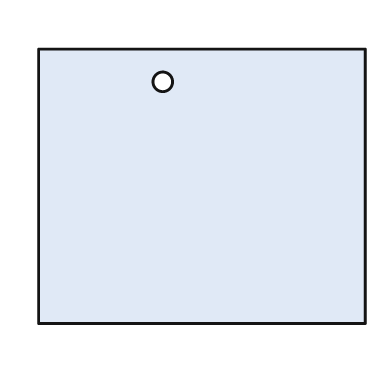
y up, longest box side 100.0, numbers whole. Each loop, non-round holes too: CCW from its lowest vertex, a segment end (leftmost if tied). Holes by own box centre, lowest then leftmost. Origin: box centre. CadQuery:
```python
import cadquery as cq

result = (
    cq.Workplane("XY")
    .moveTo(-50.0, -42.0)
    .lineTo(50.0, -42.0)
    .lineTo(50.0, 42.0)
    .lineTo(-50.0, 42.0)
    .close()
    .moveTo(-12.0, 32.0)
    .circle(3.0)
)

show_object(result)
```